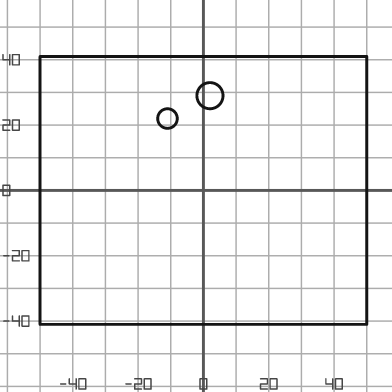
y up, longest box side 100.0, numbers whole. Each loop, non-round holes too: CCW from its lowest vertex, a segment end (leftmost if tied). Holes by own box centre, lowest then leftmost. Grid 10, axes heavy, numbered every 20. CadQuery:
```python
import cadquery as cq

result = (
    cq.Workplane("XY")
    .moveTo(-50.0, -41.0)
    .lineTo(50.0, -41.0)
    .lineTo(50.0, 41.0)
    .lineTo(-50.0, 41.0)
    .close()
    .moveTo(-11.0, 22.0)
    .circle(3.0)
    .moveTo(2.0, 29.0)
    .circle(4.0)
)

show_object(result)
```